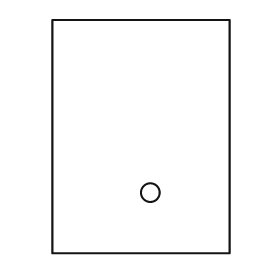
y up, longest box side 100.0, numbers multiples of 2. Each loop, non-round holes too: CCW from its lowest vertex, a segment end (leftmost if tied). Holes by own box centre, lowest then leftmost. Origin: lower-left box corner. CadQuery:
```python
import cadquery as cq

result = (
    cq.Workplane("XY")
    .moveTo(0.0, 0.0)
    .lineTo(76.0, 0.0)
    .lineTo(76.0, 100.0)
    .lineTo(0.0, 100.0)
    .close()
    .moveTo(42.0, 26.0)
    .circle(4.0)
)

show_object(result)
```